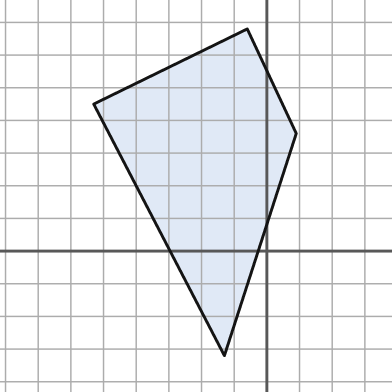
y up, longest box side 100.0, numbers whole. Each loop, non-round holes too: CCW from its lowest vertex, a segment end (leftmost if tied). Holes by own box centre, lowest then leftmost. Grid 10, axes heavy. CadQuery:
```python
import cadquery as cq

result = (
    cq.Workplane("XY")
    .moveTo(-13.0, -32.0)
    .lineTo(9.0, 36.0)
    .lineTo(-6.0, 68.0)
    .lineTo(-53.0, 45.0)
    .close()
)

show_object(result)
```